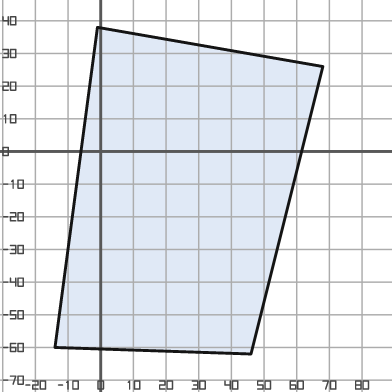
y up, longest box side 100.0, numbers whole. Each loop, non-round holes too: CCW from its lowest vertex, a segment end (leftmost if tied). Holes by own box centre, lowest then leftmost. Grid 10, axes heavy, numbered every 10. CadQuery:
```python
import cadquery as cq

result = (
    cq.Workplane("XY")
    .moveTo(46.0, -62.0)
    .lineTo(68.0, 26.0)
    .lineTo(-1.0, 38.0)
    .lineTo(-14.0, -60.0)
    .close()
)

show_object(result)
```